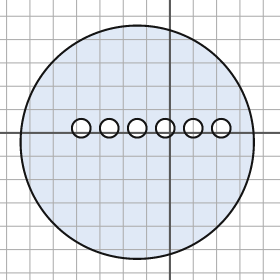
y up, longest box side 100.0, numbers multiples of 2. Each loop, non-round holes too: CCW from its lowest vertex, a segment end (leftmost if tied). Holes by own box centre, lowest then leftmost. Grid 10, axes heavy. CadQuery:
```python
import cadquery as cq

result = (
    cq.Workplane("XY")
    .moveTo(-14.0, -4.0)
    .circle(50.0)
    .moveTo(-38.0, 2.0)
    .circle(4.0)
    .moveTo(-26.0, 2.0)
    .circle(4.0)
    .moveTo(-14.0, 2.0)
    .circle(4.0)
    .moveTo(-2.0, 2.0)
    .circle(4.0)
    .moveTo(10.0, 2.0)
    .circle(4.0)
    .moveTo(22.0, 2.0)
    .circle(4.0)
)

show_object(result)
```